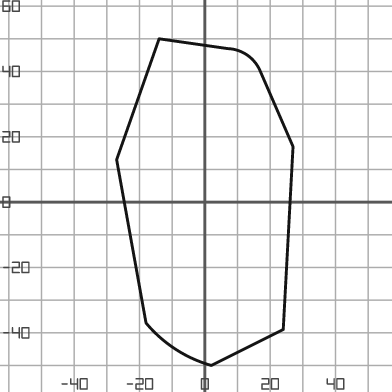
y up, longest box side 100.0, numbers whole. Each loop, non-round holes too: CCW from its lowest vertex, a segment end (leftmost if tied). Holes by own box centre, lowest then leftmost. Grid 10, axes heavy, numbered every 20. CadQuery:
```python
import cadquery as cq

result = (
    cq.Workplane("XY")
    .moveTo(2.0, -50.0)
    .lineTo(24.0, -39.0)
    .lineTo(27.0, 17.0)
    .lineTo(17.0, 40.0)
    .threePointArc((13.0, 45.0), (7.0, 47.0))
    .lineTo(-14.0, 50.0)
    .lineTo(-27.0, 13.0)
    .lineTo(-18.0, -37.0)
    .threePointArc((-9.0, -45.0), (2.0, -50.0))
    .close()
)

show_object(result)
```